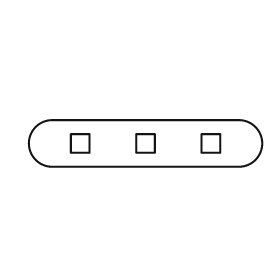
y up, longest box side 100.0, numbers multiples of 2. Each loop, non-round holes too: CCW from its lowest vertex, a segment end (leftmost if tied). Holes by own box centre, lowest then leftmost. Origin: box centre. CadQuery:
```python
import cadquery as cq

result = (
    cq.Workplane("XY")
    .moveTo(-40.0, -10.0)
    .lineTo(40.0, -10.0)
    .threePointArc((50.0, 0.0), (40.0, 10.0))
    .lineTo(-40.0, 10.0)
    .threePointArc((-50.0, 0.0), (-40.0, -10.0))
    .close()
    .moveTo(-32.0, -4.0)
    .lineTo(-24.0, -4.0)
    .lineTo(-24.0, 4.0)
    .lineTo(-32.0, 4.0)
    .close()
    .moveTo(-4.0, -4.0)
    .lineTo(4.0, -4.0)
    .lineTo(4.0, 4.0)
    .lineTo(-4.0, 4.0)
    .close()
    .moveTo(24.0, -4.0)
    .lineTo(32.0, -4.0)
    .lineTo(32.0, 4.0)
    .lineTo(24.0, 4.0)
    .close()
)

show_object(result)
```